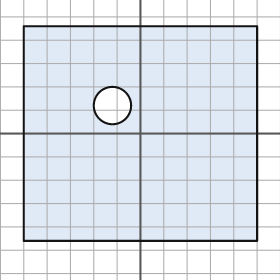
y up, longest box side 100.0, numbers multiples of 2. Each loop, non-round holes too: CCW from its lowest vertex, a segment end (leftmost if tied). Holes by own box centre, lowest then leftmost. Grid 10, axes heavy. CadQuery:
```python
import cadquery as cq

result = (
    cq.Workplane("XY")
    .moveTo(-50.0, -46.0)
    .lineTo(50.0, -46.0)
    .lineTo(50.0, 46.0)
    .lineTo(-50.0, 46.0)
    .close()
    .moveTo(-12.0, 12.0)
    .circle(8.0)
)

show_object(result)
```